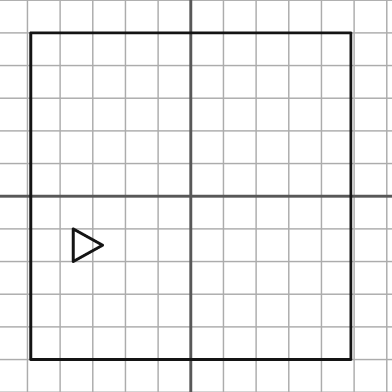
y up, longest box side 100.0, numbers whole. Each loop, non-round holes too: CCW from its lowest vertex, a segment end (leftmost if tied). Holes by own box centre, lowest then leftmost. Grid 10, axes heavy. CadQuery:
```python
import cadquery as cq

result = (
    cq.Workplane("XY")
    .moveTo(-49.0, -50.0)
    .lineTo(49.0, -50.0)
    .lineTo(49.0, 50.0)
    .lineTo(-49.0, 50.0)
    .close()
    .moveTo(-36.0, -20.0)
    .lineTo(-27.0, -15.0)
    .lineTo(-36.0, -10.0)
    .close()
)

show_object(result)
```